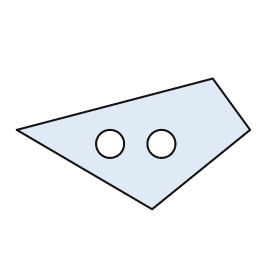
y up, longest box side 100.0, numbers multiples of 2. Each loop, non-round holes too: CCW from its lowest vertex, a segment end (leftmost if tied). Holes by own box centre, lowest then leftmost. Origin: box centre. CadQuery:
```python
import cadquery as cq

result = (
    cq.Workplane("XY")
    .moveTo(8.0, -28.0)
    .lineTo(50.0, 6.0)
    .lineTo(34.0, 28.0)
    .lineTo(-50.0, 6.0)
    .close()
    .moveTo(-10.0, 0.0)
    .circle(6.0)
    .moveTo(12.0, 0.0)
    .circle(6.0)
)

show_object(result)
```